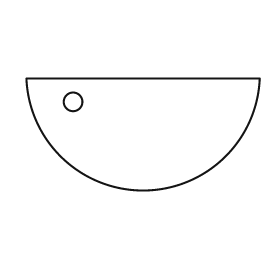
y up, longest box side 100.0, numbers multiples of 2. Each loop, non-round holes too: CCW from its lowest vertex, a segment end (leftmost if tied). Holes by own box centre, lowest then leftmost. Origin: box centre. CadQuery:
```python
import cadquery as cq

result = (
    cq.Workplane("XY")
    .moveTo(-50.0, 24.0)
    .threePointArc((0.0, -24.0), (50.0, 24.0))
    .close()
    .moveTo(-30.0, 14.0)
    .circle(4.0)
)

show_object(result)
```